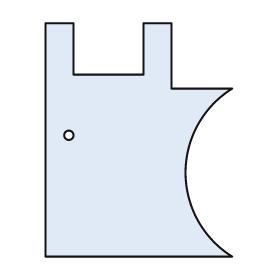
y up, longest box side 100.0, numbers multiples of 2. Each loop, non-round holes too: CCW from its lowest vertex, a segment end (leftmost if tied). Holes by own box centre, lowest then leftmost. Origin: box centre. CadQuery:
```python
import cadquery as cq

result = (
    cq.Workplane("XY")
    .moveTo(-40.0, -50.0)
    .lineTo(40.0, -50.0)
    .threePointArc((20.0, -14.0), (40.0, 22.0))
    .lineTo(14.0, 22.0)
    .lineTo(14.0, 50.0)
    .lineTo(2.0, 50.0)
    .lineTo(2.0, 28.0)
    .lineTo(-28.0, 28.0)
    .lineTo(-28.0, 50.0)
    .lineTo(-40.0, 50.0)
    .close()
    .moveTo(-30.0, 2.0)
    .circle(2.0)
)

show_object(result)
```